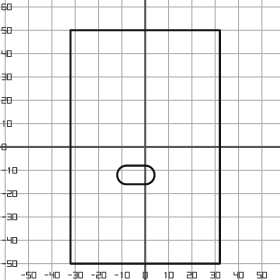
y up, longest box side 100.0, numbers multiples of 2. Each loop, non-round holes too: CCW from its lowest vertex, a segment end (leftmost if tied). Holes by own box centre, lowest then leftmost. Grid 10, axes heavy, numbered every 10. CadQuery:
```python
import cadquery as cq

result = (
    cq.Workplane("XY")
    .moveTo(-32.0, -50.0)
    .lineTo(32.0, -50.0)
    .lineTo(32.0, 50.0)
    .lineTo(-32.0, 50.0)
    .close()
    .moveTo(-8.0, -16.0)
    .lineTo(0.0, -16.0)
    .threePointArc((4.0, -12.0), (0.0, -8.0))
    .lineTo(-8.0, -8.0)
    .threePointArc((-12.0, -12.0), (-8.0, -16.0))
    .close()
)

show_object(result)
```